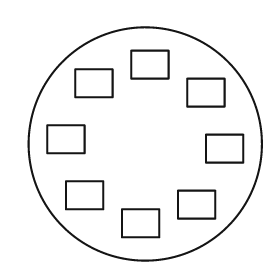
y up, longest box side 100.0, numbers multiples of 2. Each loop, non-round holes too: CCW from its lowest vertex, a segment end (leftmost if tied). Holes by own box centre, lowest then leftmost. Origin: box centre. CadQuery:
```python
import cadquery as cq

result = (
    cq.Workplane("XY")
    .moveTo(0.0, 0.0)
    .circle(50.0)
    .moveTo(-10.0, -40.0)
    .lineTo(6.0, -40.0)
    .lineTo(6.0, -28.0)
    .lineTo(-10.0, -28.0)
    .close()
    .moveTo(14.0, -32.0)
    .lineTo(30.0, -32.0)
    .lineTo(30.0, -20.0)
    .lineTo(14.0, -20.0)
    .close()
    .moveTo(-34.0, -28.0)
    .lineTo(-18.0, -28.0)
    .lineTo(-18.0, -16.0)
    .lineTo(-34.0, -16.0)
    .close()
    .moveTo(26.0, -8.0)
    .lineTo(42.0, -8.0)
    .lineTo(42.0, 4.0)
    .lineTo(26.0, 4.0)
    .close()
    .moveTo(-42.0, -4.0)
    .lineTo(-26.0, -4.0)
    .lineTo(-26.0, 8.0)
    .lineTo(-42.0, 8.0)
    .close()
    .moveTo(18.0, 16.0)
    .lineTo(34.0, 16.0)
    .lineTo(34.0, 28.0)
    .lineTo(18.0, 28.0)
    .close()
    .moveTo(-30.0, 20.0)
    .lineTo(-14.0, 20.0)
    .lineTo(-14.0, 32.0)
    .lineTo(-30.0, 32.0)
    .close()
    .moveTo(-6.0, 28.0)
    .lineTo(10.0, 28.0)
    .lineTo(10.0, 40.0)
    .lineTo(-6.0, 40.0)
    .close()
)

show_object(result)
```